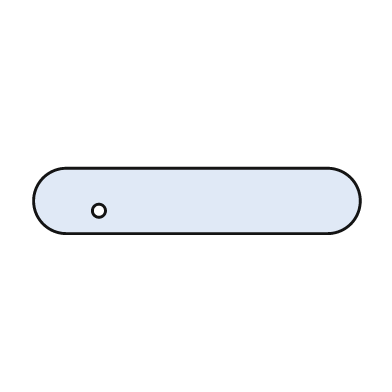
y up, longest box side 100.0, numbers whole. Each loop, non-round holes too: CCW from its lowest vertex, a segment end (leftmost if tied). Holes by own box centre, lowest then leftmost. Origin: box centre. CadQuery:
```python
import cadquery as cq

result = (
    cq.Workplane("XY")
    .moveTo(-40.0, -10.0)
    .lineTo(40.0, -10.0)
    .threePointArc((50.0, 0.0), (40.0, 10.0))
    .lineTo(-40.0, 10.0)
    .threePointArc((-50.0, 0.0), (-40.0, -10.0))
    .close()
    .moveTo(-30.0, -3.0)
    .circle(2.0)
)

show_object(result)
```